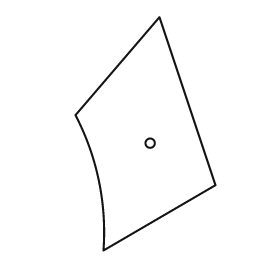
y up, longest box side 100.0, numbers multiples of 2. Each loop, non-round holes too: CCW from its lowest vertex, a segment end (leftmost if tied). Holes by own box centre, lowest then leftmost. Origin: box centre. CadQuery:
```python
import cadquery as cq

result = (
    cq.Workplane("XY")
    .moveTo(-18.0, -50.0)
    .lineTo(30.0, -22.0)
    .lineTo(6.0, 50.0)
    .lineTo(-30.0, 8.0)
    .threePointArc((-20.0, -20.0), (-18.0, -50.0))
    .close()
    .moveTo(2.0, -4.0)
    .circle(2.0)
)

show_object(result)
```